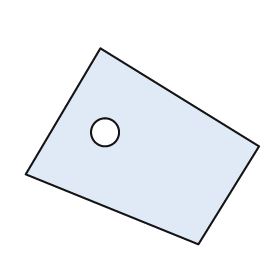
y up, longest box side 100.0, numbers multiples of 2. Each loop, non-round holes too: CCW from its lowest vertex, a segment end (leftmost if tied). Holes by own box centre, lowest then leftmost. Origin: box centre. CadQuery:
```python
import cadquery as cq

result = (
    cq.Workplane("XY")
    .moveTo(24.0, -42.0)
    .lineTo(50.0, 0.0)
    .lineTo(-18.0, 42.0)
    .lineTo(-50.0, -12.0)
    .close()
    .moveTo(-16.0, 6.0)
    .circle(6.0)
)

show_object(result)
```